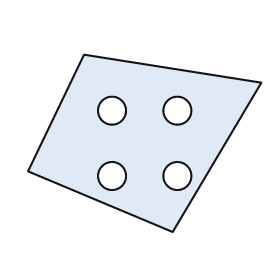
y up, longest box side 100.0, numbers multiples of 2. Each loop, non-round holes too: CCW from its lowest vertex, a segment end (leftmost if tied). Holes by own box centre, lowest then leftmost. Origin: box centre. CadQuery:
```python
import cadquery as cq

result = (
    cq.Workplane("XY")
    .moveTo(12.0, -38.0)
    .lineTo(50.0, 26.0)
    .lineTo(-26.0, 38.0)
    .lineTo(-50.0, -12.0)
    .close()
    .moveTo(-14.0, -14.0)
    .circle(6.0)
    .moveTo(14.0, -14.0)
    .circle(6.0)
    .moveTo(-14.0, 14.0)
    .circle(6.0)
    .moveTo(14.0, 14.0)
    .circle(6.0)
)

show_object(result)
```